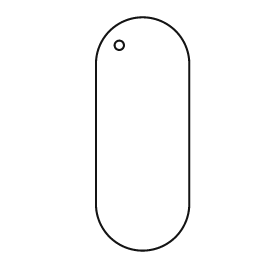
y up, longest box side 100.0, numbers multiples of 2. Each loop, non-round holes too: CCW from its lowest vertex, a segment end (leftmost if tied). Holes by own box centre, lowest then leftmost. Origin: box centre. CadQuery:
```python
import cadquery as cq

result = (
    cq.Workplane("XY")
    .moveTo(-20.0, -30.0)
    .threePointArc((0.0, -50.0), (20.0, -30.0))
    .lineTo(20.0, 30.0)
    .threePointArc((0.0, 50.0), (-20.0, 30.0))
    .close()
    .moveTo(-10.0, 38.0)
    .circle(2.0)
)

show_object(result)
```